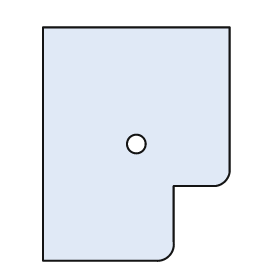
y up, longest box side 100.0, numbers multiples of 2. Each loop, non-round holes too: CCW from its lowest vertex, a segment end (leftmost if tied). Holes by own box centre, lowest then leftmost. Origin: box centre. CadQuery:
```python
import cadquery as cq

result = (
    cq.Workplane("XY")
    .moveTo(-40.0, -50.0)
    .lineTo(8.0, -50.0)
    .threePointArc((14.0, -48.0), (16.0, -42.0))
    .lineTo(16.0, -18.0)
    .lineTo(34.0, -18.0)
    .threePointArc((38.0, -16.0), (40.0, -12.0))
    .lineTo(40.0, 50.0)
    .lineTo(-40.0, 50.0)
    .close()
    .moveTo(0.0, 0.0)
    .circle(4.0)
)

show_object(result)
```